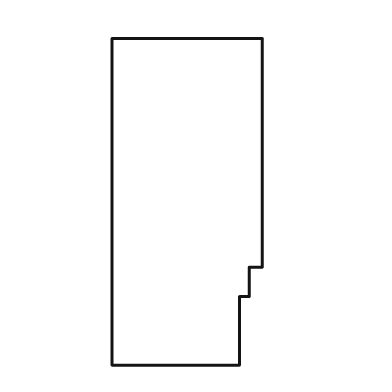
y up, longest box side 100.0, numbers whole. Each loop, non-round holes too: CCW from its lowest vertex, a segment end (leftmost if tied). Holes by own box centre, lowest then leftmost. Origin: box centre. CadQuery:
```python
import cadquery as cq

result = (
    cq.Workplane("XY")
    .moveTo(-23.0, -50.0)
    .lineTo(16.0, -50.0)
    .lineTo(16.0, -29.0)
    .lineTo(19.0, -29.0)
    .lineTo(19.0, -20.0)
    .lineTo(23.0, -20.0)
    .lineTo(23.0, 50.0)
    .lineTo(-23.0, 50.0)
    .close()
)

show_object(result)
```